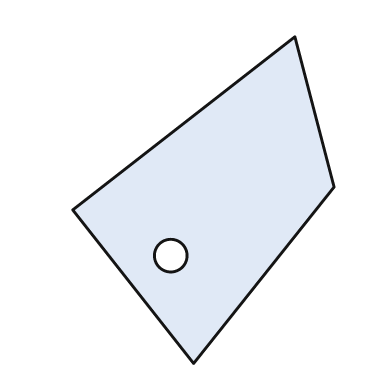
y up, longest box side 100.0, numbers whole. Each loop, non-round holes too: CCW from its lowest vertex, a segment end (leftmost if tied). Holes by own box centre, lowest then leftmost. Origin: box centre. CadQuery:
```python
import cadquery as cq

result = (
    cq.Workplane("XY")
    .moveTo(-3.0, -50.0)
    .lineTo(40.0, 4.0)
    .lineTo(28.0, 50.0)
    .lineTo(-40.0, -3.0)
    .close()
    .moveTo(-10.0, -17.0)
    .circle(5.0)
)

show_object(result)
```